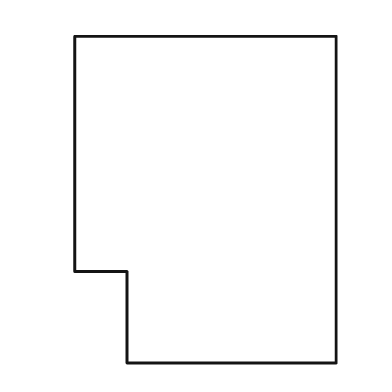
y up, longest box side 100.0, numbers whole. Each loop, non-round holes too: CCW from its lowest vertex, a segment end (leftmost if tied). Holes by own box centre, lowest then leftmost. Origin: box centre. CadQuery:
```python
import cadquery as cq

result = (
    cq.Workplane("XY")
    .moveTo(-24.0, -50.0)
    .lineTo(40.0, -50.0)
    .lineTo(40.0, 50.0)
    .lineTo(-40.0, 50.0)
    .lineTo(-40.0, -22.0)
    .lineTo(-24.0, -22.0)
    .close()
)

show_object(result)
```